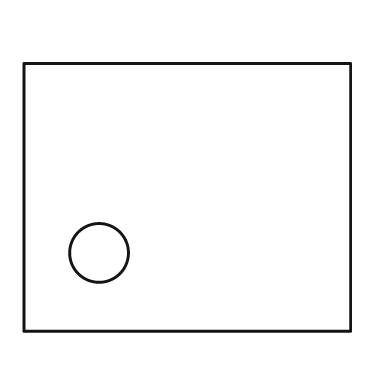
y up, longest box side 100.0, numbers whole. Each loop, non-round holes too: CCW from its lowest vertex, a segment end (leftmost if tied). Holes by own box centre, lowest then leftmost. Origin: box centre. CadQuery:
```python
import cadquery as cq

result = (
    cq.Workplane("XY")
    .moveTo(-50.0, -41.0)
    .lineTo(50.0, -41.0)
    .lineTo(50.0, 41.0)
    .lineTo(-50.0, 41.0)
    .close()
    .moveTo(-27.0, -17.0)
    .circle(9.0)
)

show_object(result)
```